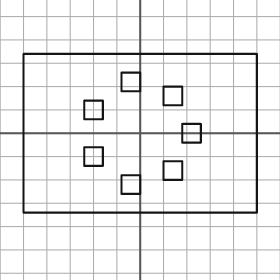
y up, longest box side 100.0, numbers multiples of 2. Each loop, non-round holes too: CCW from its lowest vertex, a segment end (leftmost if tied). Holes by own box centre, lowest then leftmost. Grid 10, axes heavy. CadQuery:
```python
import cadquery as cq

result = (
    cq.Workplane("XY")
    .moveTo(-50.0, -34.0)
    .lineTo(50.0, -34.0)
    .lineTo(50.0, 34.0)
    .lineTo(-50.0, 34.0)
    .close()
    .moveTo(-8.0, -26.0)
    .lineTo(0.0, -26.0)
    .lineTo(0.0, -18.0)
    .lineTo(-8.0, -18.0)
    .close()
    .moveTo(10.0, -20.0)
    .lineTo(18.0, -20.0)
    .lineTo(18.0, -12.0)
    .lineTo(10.0, -12.0)
    .close()
    .moveTo(-24.0, -14.0)
    .lineTo(-16.0, -14.0)
    .lineTo(-16.0, -6.0)
    .lineTo(-24.0, -6.0)
    .close()
    .moveTo(18.0, -4.0)
    .lineTo(26.0, -4.0)
    .lineTo(26.0, 4.0)
    .lineTo(18.0, 4.0)
    .close()
    .moveTo(-24.0, 6.0)
    .lineTo(-16.0, 6.0)
    .lineTo(-16.0, 14.0)
    .lineTo(-24.0, 14.0)
    .close()
    .moveTo(10.0, 12.0)
    .lineTo(18.0, 12.0)
    .lineTo(18.0, 20.0)
    .lineTo(10.0, 20.0)
    .close()
    .moveTo(-8.0, 18.0)
    .lineTo(0.0, 18.0)
    .lineTo(0.0, 26.0)
    .lineTo(-8.0, 26.0)
    .close()
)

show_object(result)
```